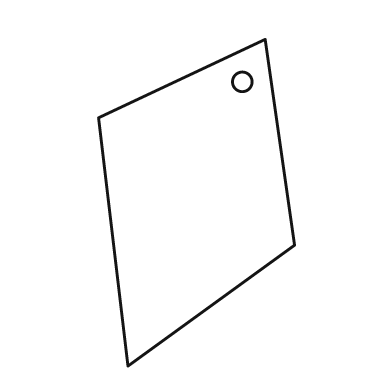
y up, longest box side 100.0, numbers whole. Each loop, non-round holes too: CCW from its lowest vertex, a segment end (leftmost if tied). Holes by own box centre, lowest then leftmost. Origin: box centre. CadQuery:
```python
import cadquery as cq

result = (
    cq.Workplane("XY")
    .moveTo(-21.0, -50.0)
    .lineTo(30.0, -13.0)
    .lineTo(21.0, 50.0)
    .lineTo(-30.0, 26.0)
    .close()
    .moveTo(14.0, 37.0)
    .circle(3.0)
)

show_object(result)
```